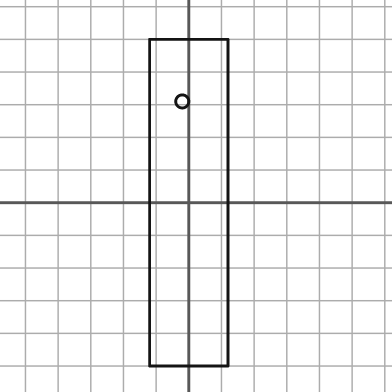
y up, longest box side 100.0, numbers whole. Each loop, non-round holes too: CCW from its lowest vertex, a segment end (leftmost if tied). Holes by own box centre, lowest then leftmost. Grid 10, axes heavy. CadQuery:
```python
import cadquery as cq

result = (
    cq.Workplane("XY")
    .moveTo(-12.0, -50.0)
    .lineTo(12.0, -50.0)
    .lineTo(12.0, 50.0)
    .lineTo(-12.0, 50.0)
    .close()
    .moveTo(-2.0, 31.0)
    .circle(2.0)
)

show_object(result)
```